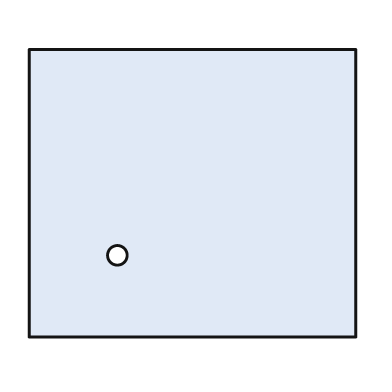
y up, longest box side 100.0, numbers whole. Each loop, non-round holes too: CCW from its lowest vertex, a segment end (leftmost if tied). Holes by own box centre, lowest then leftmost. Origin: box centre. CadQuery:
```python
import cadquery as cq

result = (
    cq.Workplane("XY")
    .moveTo(-50.0, -44.0)
    .lineTo(50.0, -44.0)
    .lineTo(50.0, 44.0)
    .lineTo(-50.0, 44.0)
    .close()
    .moveTo(-23.0, -19.0)
    .circle(3.0)
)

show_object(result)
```